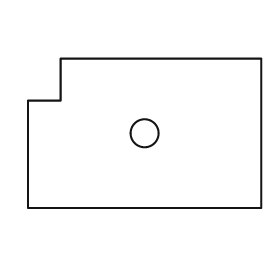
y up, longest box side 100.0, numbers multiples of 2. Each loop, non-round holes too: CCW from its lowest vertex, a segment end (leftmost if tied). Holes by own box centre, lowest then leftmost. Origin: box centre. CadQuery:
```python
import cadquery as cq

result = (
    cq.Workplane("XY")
    .moveTo(-50.0, -32.0)
    .lineTo(50.0, -32.0)
    .lineTo(50.0, 32.0)
    .lineTo(-36.0, 32.0)
    .lineTo(-36.0, 14.0)
    .lineTo(-50.0, 14.0)
    .close()
    .moveTo(0.0, 0.0)
    .circle(6.0)
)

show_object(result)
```